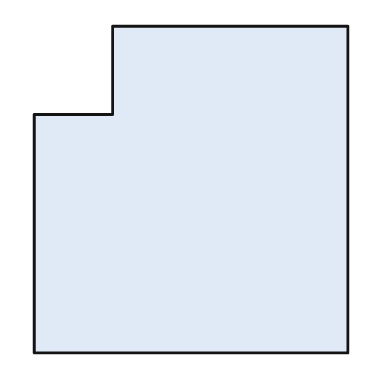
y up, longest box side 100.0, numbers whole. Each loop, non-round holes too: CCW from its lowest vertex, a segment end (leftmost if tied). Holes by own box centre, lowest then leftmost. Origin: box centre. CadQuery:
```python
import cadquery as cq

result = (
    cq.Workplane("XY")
    .moveTo(-48.0, -50.0)
    .lineTo(48.0, -50.0)
    .lineTo(48.0, 50.0)
    .lineTo(-24.0, 50.0)
    .lineTo(-24.0, 23.0)
    .lineTo(-48.0, 23.0)
    .close()
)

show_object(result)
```